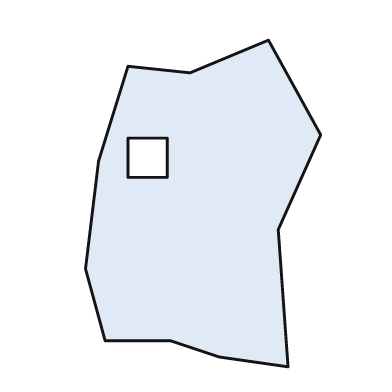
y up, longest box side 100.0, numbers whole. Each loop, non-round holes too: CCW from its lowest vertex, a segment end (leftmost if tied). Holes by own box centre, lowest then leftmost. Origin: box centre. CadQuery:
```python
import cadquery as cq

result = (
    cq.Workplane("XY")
    .moveTo(26.0, -50.0)
    .lineTo(23.0, -8.0)
    .lineTo(36.0, 21.0)
    .lineTo(20.0, 50.0)
    .lineTo(-4.0, 40.0)
    .lineTo(-23.0, 42.0)
    .lineTo(-32.0, 13.0)
    .lineTo(-36.0, -20.0)
    .lineTo(-30.0, -42.0)
    .lineTo(-10.0, -42.0)
    .lineTo(5.0, -47.0)
    .close()
    .moveTo(-23.0, 8.0)
    .lineTo(-11.0, 8.0)
    .lineTo(-11.0, 20.0)
    .lineTo(-23.0, 20.0)
    .close()
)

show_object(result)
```